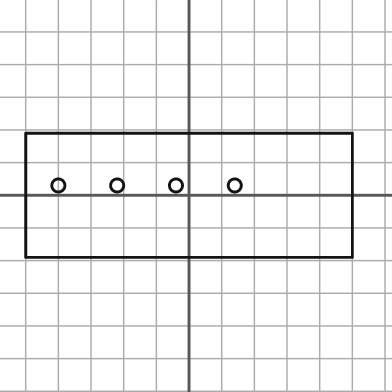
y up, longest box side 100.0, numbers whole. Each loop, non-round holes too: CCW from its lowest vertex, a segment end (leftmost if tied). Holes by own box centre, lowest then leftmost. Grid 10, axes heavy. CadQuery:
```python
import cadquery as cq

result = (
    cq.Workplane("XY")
    .moveTo(-50.0, -19.0)
    .lineTo(50.0, -19.0)
    .lineTo(50.0, 19.0)
    .lineTo(-50.0, 19.0)
    .close()
    .moveTo(-40.0, 3.0)
    .circle(2.0)
    .moveTo(-22.0, 3.0)
    .circle(2.0)
    .moveTo(-4.0, 3.0)
    .circle(2.0)
    .moveTo(14.0, 3.0)
    .circle(2.0)
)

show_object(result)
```